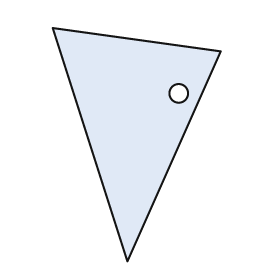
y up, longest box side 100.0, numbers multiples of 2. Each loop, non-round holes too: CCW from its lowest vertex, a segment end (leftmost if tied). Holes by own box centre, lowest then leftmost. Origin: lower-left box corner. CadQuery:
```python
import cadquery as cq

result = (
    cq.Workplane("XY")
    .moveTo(32.0, 0.0)
    .lineTo(72.0, 90.0)
    .lineTo(0.0, 100.0)
    .close()
    .moveTo(54.0, 72.0)
    .circle(4.0)
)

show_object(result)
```